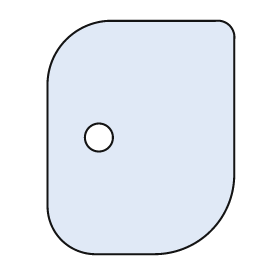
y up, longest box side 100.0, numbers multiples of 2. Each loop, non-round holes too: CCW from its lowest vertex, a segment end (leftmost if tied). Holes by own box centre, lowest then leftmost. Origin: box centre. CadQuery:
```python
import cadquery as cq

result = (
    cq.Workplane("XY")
    .moveTo(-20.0, -50.0)
    .lineTo(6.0, -50.0)
    .threePointArc((30.0, -40.0), (40.0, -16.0))
    .lineTo(40.0, 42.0)
    .threePointArc((38.0, 48.0), (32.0, 50.0))
    .lineTo(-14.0, 50.0)
    .threePointArc((-32.0, 42.0), (-40.0, 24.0))
    .lineTo(-40.0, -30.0)
    .threePointArc((-34.0, -44.0), (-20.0, -50.0))
    .close()
    .moveTo(-18.0, 0.0)
    .circle(6.0)
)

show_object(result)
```